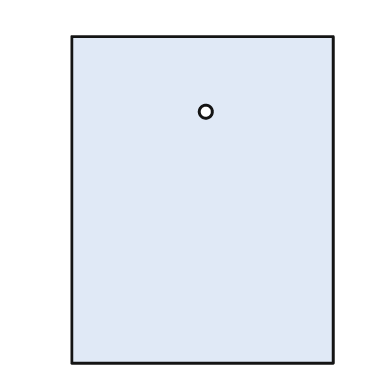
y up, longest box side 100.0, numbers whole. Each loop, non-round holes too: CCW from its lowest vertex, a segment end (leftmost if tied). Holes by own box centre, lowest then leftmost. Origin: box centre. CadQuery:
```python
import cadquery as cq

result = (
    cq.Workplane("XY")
    .moveTo(-40.0, -50.0)
    .lineTo(40.0, -50.0)
    .lineTo(40.0, 50.0)
    .lineTo(-40.0, 50.0)
    .close()
    .moveTo(1.0, 27.0)
    .circle(2.0)
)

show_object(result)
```